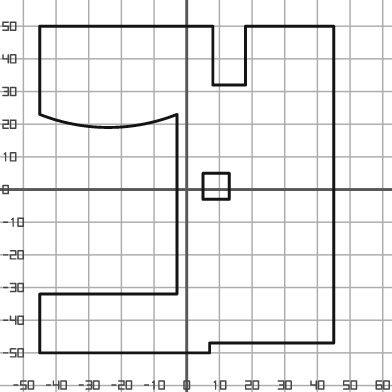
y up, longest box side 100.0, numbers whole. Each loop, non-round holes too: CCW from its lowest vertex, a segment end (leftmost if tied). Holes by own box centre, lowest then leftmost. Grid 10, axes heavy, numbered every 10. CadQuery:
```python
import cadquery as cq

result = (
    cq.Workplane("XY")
    .moveTo(-45.0, -50.0)
    .lineTo(7.0, -50.0)
    .lineTo(7.0, -47.0)
    .lineTo(45.0, -47.0)
    .lineTo(45.0, 50.0)
    .lineTo(18.0, 50.0)
    .lineTo(18.0, 32.0)
    .lineTo(8.0, 32.0)
    .lineTo(8.0, 50.0)
    .lineTo(-45.0, 50.0)
    .lineTo(-45.0, 23.0)
    .threePointArc((-24.0, 19.0), (-3.0, 23.0))
    .lineTo(-3.0, -32.0)
    .lineTo(-45.0, -32.0)
    .close()
    .moveTo(5.0, -3.0)
    .lineTo(13.0, -3.0)
    .lineTo(13.0, 5.0)
    .lineTo(5.0, 5.0)
    .close()
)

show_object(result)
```